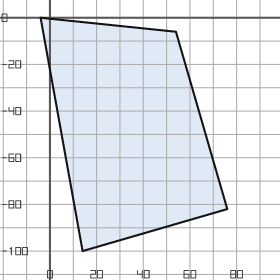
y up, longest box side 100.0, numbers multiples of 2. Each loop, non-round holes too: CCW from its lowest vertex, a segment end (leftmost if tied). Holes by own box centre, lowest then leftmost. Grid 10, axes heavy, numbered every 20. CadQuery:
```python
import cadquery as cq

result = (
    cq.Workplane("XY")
    .moveTo(14.0, -100.0)
    .lineTo(76.0, -82.0)
    .lineTo(54.0, -6.0)
    .lineTo(-4.0, 0.0)
    .close()
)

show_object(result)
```